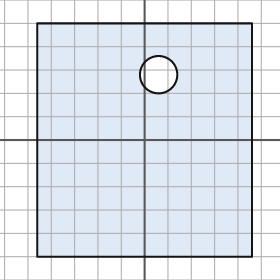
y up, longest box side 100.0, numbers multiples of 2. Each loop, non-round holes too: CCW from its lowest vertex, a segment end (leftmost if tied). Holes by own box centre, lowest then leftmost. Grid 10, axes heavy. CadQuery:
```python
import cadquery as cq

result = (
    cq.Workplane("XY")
    .moveTo(-46.0, -50.0)
    .lineTo(46.0, -50.0)
    .lineTo(46.0, 50.0)
    .lineTo(-46.0, 50.0)
    .close()
    .moveTo(6.0, 28.0)
    .circle(8.0)
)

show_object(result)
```